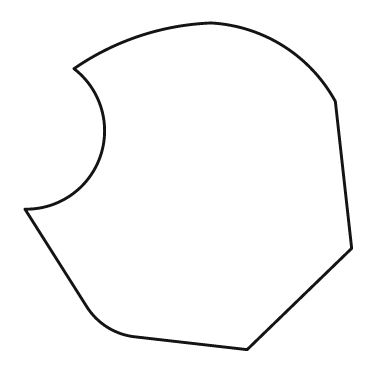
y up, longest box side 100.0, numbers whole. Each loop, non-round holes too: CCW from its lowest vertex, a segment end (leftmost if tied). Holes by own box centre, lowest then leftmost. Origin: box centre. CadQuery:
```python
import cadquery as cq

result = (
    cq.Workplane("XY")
    .moveTo(18.0, -50.0)
    .lineTo(50.0, -19.0)
    .lineTo(45.0, 26.0)
    .threePointArc((29.0, 43.0), (7.0, 50.0))
    .threePointArc((-15.0, 46.0), (-35.0, 36.0))
    .threePointArc((-27.0, 9.0), (-50.0, -7.0))
    .lineTo(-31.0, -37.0)
    .threePointArc((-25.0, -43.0), (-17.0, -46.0))
    .close()
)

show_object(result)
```